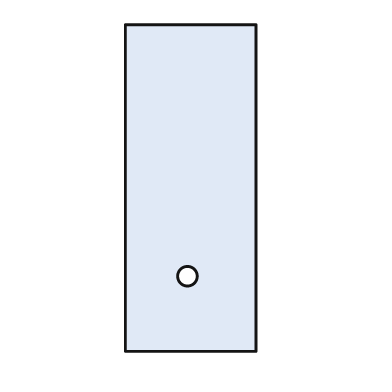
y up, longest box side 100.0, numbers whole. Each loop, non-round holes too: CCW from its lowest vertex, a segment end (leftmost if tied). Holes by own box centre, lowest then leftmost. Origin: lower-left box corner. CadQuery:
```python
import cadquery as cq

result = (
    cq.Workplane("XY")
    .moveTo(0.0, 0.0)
    .lineTo(40.0, 0.0)
    .lineTo(40.0, 100.0)
    .lineTo(0.0, 100.0)
    .close()
    .moveTo(19.0, 23.0)
    .circle(3.0)
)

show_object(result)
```